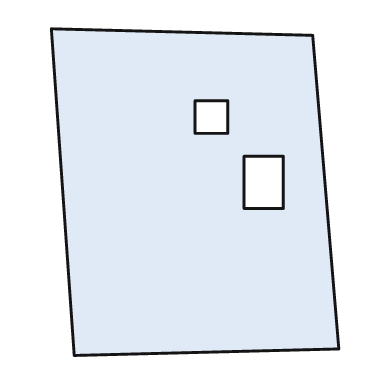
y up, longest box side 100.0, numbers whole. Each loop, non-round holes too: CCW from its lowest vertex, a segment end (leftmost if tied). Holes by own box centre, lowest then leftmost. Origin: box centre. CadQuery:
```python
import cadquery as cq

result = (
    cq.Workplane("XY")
    .moveTo(-37.0, -50.0)
    .lineTo(44.0, -48.0)
    .lineTo(36.0, 48.0)
    .lineTo(-44.0, 50.0)
    .close()
    .moveTo(15.0, -5.0)
    .lineTo(27.0, -5.0)
    .lineTo(27.0, 11.0)
    .lineTo(15.0, 11.0)
    .close()
    .moveTo(0.0, 18.0)
    .lineTo(10.0, 18.0)
    .lineTo(10.0, 28.0)
    .lineTo(0.0, 28.0)
    .close()
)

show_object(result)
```